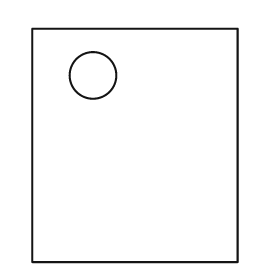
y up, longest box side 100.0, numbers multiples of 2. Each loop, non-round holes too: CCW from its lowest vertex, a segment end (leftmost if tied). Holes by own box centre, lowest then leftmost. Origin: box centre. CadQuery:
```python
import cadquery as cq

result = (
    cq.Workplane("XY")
    .moveTo(-44.0, -50.0)
    .lineTo(44.0, -50.0)
    .lineTo(44.0, 50.0)
    .lineTo(-44.0, 50.0)
    .close()
    .moveTo(-18.0, 30.0)
    .circle(10.0)
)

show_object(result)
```